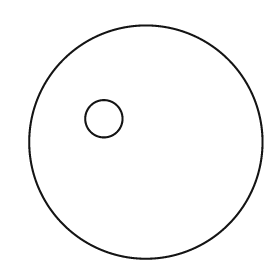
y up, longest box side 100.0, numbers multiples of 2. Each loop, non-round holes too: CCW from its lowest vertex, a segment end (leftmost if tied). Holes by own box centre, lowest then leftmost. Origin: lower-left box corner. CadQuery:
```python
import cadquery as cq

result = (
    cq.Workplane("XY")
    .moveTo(50.0, 50.0)
    .circle(50.0)
    .moveTo(32.0, 60.0)
    .circle(8.0)
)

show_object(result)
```